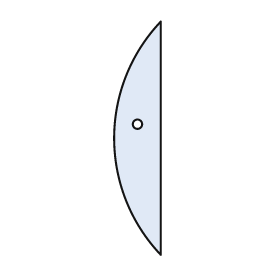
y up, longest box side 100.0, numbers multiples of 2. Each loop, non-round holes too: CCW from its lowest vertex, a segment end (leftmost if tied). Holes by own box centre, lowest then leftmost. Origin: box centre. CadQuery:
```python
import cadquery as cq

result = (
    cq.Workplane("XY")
    .moveTo(10.0, -50.0)
    .lineTo(10.0, 50.0)
    .threePointArc((-10.0, 0.0), (10.0, -50.0))
    .close()
    .moveTo(0.0, 6.0)
    .circle(2.0)
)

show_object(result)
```